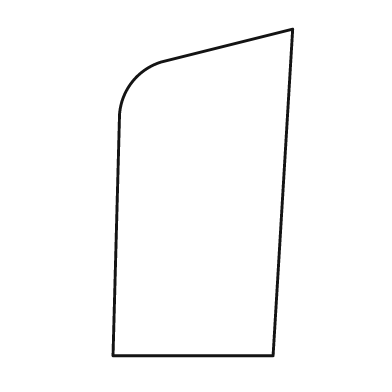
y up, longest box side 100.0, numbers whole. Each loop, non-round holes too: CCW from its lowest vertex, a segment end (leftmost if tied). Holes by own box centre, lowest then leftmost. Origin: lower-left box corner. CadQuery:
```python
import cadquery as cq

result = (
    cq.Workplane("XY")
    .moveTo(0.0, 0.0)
    .lineTo(49.0, 0.0)
    .lineTo(55.0, 100.0)
    .lineTo(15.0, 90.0)
    .threePointArc((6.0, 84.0), (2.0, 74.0))
    .close()
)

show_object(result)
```